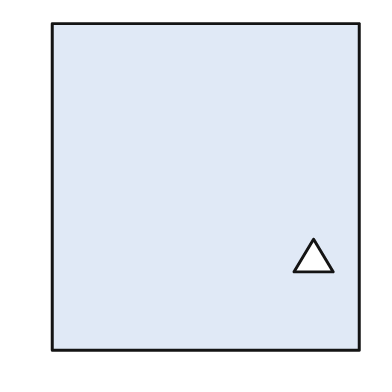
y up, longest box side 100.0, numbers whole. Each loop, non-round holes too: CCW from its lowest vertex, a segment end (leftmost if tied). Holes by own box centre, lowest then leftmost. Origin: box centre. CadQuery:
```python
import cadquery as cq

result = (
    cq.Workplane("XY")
    .moveTo(-47.0, -50.0)
    .lineTo(47.0, -50.0)
    .lineTo(47.0, 50.0)
    .lineTo(-47.0, 50.0)
    .close()
    .moveTo(27.0, -26.0)
    .lineTo(39.0, -26.0)
    .lineTo(33.0, -16.0)
    .close()
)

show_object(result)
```